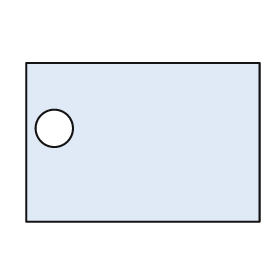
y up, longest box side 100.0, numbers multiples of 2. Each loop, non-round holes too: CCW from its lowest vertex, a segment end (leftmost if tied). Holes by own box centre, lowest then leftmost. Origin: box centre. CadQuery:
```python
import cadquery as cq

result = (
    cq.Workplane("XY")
    .moveTo(-50.0, -34.0)
    .lineTo(50.0, -34.0)
    .lineTo(50.0, 34.0)
    .lineTo(-50.0, 34.0)
    .close()
    .moveTo(-38.0, 6.0)
    .circle(8.0)
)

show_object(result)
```